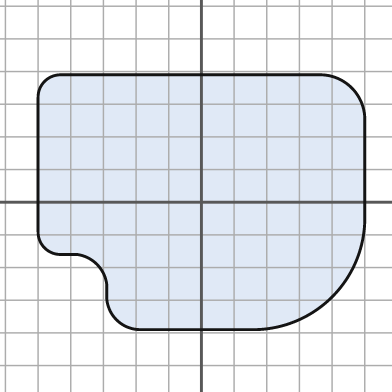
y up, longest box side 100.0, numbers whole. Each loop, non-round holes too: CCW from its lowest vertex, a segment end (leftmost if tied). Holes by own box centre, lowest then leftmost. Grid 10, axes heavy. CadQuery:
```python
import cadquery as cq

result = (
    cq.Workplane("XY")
    .moveTo(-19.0, -39.0)
    .lineTo(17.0, -39.0)
    .threePointArc((40.0, -29.0), (50.0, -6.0))
    .lineTo(50.0, 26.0)
    .threePointArc((46.0, 35.0), (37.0, 39.0))
    .lineTo(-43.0, 39.0)
    .threePointArc((-48.0, 37.0), (-50.0, 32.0))
    .lineTo(-50.0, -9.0)
    .threePointArc((-48.0, -14.0), (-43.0, -16.0))
    .lineTo(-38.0, -16.0)
    .threePointArc((-32.0, -19.0), (-29.0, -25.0))
    .lineTo(-29.0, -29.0)
    .threePointArc((-26.0, -36.0), (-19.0, -39.0))
    .close()
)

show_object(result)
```